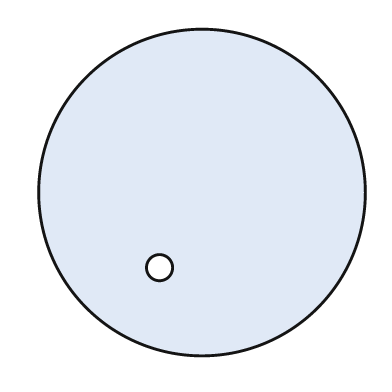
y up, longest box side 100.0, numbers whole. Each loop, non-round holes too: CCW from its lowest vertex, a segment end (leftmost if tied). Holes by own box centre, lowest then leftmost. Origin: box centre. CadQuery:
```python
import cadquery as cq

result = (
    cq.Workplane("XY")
    .moveTo(0.0, 0.0)
    .circle(50.0)
    .moveTo(-13.0, -23.0)
    .circle(4.0)
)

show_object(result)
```